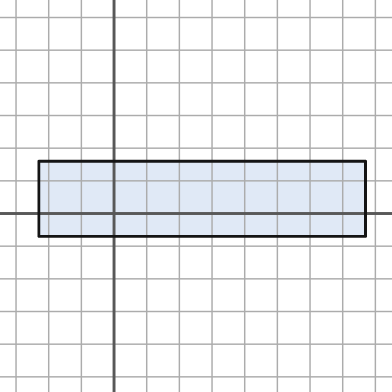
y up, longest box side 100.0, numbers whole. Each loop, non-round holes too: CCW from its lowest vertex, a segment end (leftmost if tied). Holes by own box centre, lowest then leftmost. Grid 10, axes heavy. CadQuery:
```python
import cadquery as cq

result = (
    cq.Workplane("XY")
    .moveTo(-23.0, -7.0)
    .lineTo(77.0, -7.0)
    .lineTo(77.0, 16.0)
    .lineTo(-23.0, 16.0)
    .close()
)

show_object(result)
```